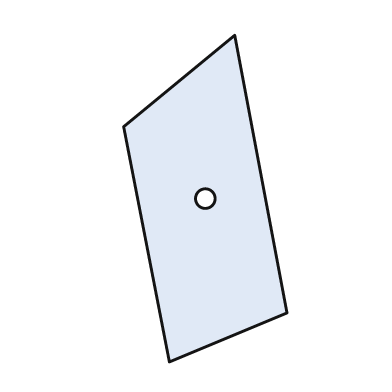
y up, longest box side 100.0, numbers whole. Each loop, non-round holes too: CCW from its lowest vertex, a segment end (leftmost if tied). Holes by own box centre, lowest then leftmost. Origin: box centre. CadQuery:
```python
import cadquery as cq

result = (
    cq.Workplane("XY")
    .moveTo(-11.0, -50.0)
    .lineTo(25.0, -35.0)
    .lineTo(9.0, 50.0)
    .lineTo(-25.0, 22.0)
    .close()
    .moveTo(0.0, 0.0)
    .circle(3.0)
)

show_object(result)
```